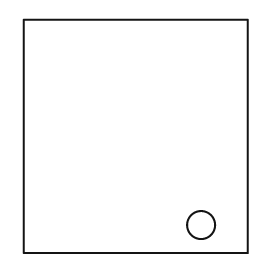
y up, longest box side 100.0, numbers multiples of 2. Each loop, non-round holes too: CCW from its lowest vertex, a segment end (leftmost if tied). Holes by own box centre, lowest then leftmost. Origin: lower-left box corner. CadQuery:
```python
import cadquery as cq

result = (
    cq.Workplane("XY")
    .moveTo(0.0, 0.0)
    .lineTo(96.0, 0.0)
    .lineTo(96.0, 100.0)
    .lineTo(0.0, 100.0)
    .close()
    .moveTo(76.0, 12.0)
    .circle(6.0)
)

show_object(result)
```